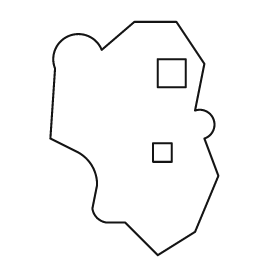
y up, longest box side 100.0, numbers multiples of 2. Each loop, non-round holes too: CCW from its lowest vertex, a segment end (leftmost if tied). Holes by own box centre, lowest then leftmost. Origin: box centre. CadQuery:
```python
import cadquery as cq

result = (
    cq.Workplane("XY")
    .moveTo(10.0, -50.0)
    .lineTo(26.0, -40.0)
    .lineTo(36.0, -16.0)
    .lineTo(30.0, 0.0)
    .threePointArc((34.0, 8.0), (26.0, 12.0))
    .lineTo(30.0, 32.0)
    .lineTo(18.0, 50.0)
    .lineTo(0.0, 50.0)
    .lineTo(-14.0, 38.0)
    .threePointArc((-28.0, 44.0), (-34.0, 30.0))
    .lineTo(-36.0, 0.0)
    .lineTo(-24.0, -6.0)
    .threePointArc((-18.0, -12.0), (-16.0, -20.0))
    .lineTo(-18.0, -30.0)
    .threePointArc((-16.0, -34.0), (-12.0, -36.0))
    .lineTo(-4.0, -36.0)
    .close()
    .moveTo(8.0, -10.0)
    .lineTo(16.0, -10.0)
    .lineTo(16.0, -2.0)
    .lineTo(8.0, -2.0)
    .close()
    .moveTo(10.0, 22.0)
    .lineTo(22.0, 22.0)
    .lineTo(22.0, 34.0)
    .lineTo(10.0, 34.0)
    .close()
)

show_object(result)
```